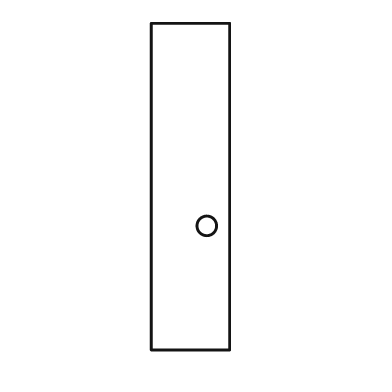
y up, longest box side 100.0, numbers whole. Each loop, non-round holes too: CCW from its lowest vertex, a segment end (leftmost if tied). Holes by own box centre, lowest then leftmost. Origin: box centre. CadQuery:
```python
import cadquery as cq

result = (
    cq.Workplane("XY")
    .moveTo(-12.0, -50.0)
    .lineTo(12.0, -50.0)
    .lineTo(12.0, 50.0)
    .lineTo(-12.0, 50.0)
    .close()
    .moveTo(5.0, -12.0)
    .circle(3.0)
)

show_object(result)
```